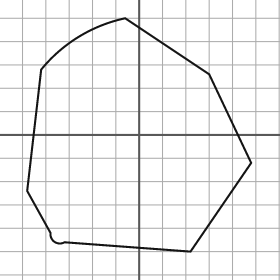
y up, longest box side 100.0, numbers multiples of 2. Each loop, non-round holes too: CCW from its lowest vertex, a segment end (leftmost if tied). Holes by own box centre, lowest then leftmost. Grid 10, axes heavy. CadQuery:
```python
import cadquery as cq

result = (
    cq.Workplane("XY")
    .moveTo(22.0, -50.0)
    .lineTo(48.0, -12.0)
    .lineTo(30.0, 26.0)
    .lineTo(-6.0, 50.0)
    .threePointArc((-26.0, 42.0), (-42.0, 28.0))
    .lineTo(-48.0, -24.0)
    .lineTo(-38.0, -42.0)
    .threePointArc((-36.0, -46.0), (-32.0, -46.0))
    .close()
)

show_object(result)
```